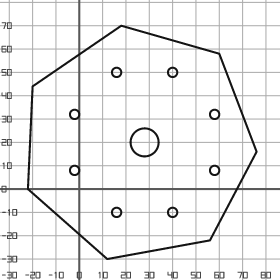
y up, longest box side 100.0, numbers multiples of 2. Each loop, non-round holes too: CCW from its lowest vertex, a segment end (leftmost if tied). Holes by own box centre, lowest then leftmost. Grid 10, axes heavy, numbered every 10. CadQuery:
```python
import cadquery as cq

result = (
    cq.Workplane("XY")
    .moveTo(12.0, -30.0)
    .lineTo(56.0, -22.0)
    .lineTo(76.0, 16.0)
    .lineTo(60.0, 58.0)
    .lineTo(18.0, 70.0)
    .lineTo(-20.0, 44.0)
    .lineTo(-22.0, 0.0)
    .close()
    .moveTo(16.0, -10.0)
    .circle(2.0)
    .moveTo(40.0, -10.0)
    .circle(2.0)
    .moveTo(-2.0, 8.0)
    .circle(2.0)
    .moveTo(58.0, 8.0)
    .circle(2.0)
    .moveTo(28.0, 20.0)
    .circle(6.0)
    .moveTo(-2.0, 32.0)
    .circle(2.0)
    .moveTo(58.0, 32.0)
    .circle(2.0)
    .moveTo(16.0, 50.0)
    .circle(2.0)
    .moveTo(40.0, 50.0)
    .circle(2.0)
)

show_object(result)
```